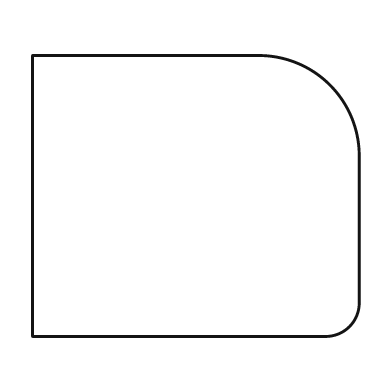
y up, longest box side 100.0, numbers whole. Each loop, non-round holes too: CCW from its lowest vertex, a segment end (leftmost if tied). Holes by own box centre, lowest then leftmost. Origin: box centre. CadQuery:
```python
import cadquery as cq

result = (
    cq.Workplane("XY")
    .moveTo(-50.0, -43.0)
    .lineTo(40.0, -43.0)
    .threePointArc((47.0, -40.0), (50.0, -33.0))
    .lineTo(50.0, 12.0)
    .threePointArc((41.0, 34.0), (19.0, 43.0))
    .lineTo(-50.0, 43.0)
    .close()
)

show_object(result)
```